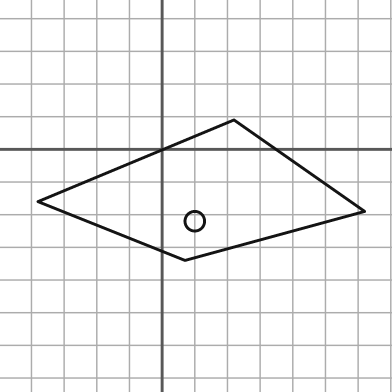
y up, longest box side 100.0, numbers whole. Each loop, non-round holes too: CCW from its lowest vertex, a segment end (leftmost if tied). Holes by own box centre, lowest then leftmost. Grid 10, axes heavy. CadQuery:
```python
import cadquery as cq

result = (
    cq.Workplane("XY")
    .moveTo(7.0, -34.0)
    .lineTo(62.0, -19.0)
    .lineTo(22.0, 9.0)
    .lineTo(-38.0, -16.0)
    .close()
    .moveTo(10.0, -22.0)
    .circle(3.0)
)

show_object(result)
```